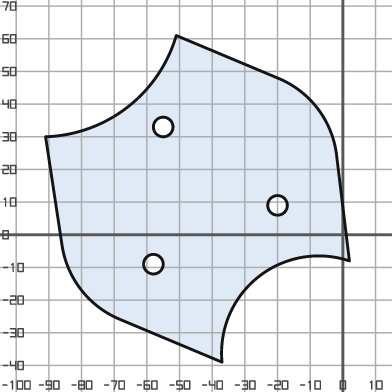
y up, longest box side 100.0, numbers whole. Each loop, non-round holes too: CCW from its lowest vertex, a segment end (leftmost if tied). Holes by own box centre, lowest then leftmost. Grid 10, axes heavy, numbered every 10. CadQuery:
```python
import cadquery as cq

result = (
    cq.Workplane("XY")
    .moveTo(-37.0, -39.0)
    .threePointArc((-26.0, -13.0), (2.0, -8.0))
    .lineTo(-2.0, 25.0)
    .threePointArc((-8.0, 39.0), (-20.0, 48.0))
    .lineTo(-51.0, 61.0)
    .threePointArc((-66.0, 39.0), (-91.0, 30.0))
    .lineTo(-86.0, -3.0)
    .threePointArc((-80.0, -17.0), (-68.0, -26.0))
    .close()
    .moveTo(-58.0, -9.0)
    .circle(3.0)
    .moveTo(-20.0, 9.0)
    .circle(3.0)
    .moveTo(-55.0, 33.0)
    .circle(3.0)
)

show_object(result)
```